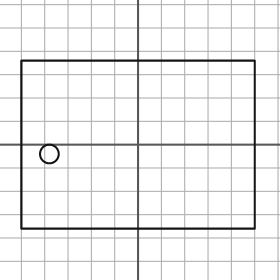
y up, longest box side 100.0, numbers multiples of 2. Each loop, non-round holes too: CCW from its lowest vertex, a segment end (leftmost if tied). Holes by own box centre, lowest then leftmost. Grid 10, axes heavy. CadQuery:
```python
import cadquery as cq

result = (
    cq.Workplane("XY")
    .moveTo(-50.0, -36.0)
    .lineTo(50.0, -36.0)
    .lineTo(50.0, 36.0)
    .lineTo(-50.0, 36.0)
    .close()
    .moveTo(-38.0, -4.0)
    .circle(4.0)
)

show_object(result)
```